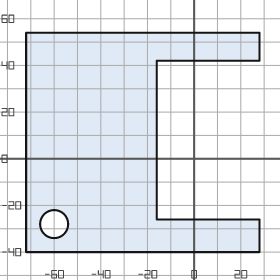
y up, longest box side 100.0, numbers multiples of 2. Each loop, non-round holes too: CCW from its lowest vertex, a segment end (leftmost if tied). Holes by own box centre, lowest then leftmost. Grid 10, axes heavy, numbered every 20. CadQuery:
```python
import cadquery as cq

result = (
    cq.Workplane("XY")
    .moveTo(-72.0, -40.0)
    .lineTo(28.0, -40.0)
    .lineTo(28.0, -26.0)
    .lineTo(-16.0, -26.0)
    .lineTo(-16.0, 42.0)
    .lineTo(28.0, 42.0)
    .lineTo(28.0, 54.0)
    .lineTo(-72.0, 54.0)
    .close()
    .moveTo(-60.0, -28.0)
    .circle(6.0)
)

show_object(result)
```